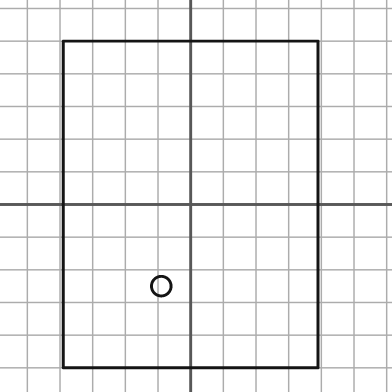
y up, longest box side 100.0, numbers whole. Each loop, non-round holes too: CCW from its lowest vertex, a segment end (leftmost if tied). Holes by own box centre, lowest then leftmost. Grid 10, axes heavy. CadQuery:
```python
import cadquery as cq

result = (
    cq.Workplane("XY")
    .moveTo(-39.0, -50.0)
    .lineTo(39.0, -50.0)
    .lineTo(39.0, 50.0)
    .lineTo(-39.0, 50.0)
    .close()
    .moveTo(-9.0, -25.0)
    .circle(3.0)
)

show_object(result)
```